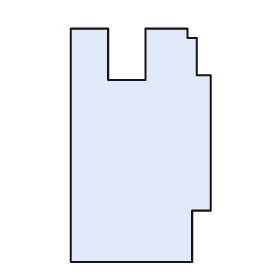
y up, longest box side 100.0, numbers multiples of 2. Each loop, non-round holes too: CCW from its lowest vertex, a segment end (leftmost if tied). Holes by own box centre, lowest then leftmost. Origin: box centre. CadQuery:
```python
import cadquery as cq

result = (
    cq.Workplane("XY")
    .moveTo(-30.0, -50.0)
    .lineTo(22.0, -50.0)
    .lineTo(22.0, -28.0)
    .lineTo(30.0, -28.0)
    .lineTo(30.0, 30.0)
    .lineTo(24.0, 30.0)
    .lineTo(24.0, 46.0)
    .lineTo(20.0, 46.0)
    .lineTo(20.0, 50.0)
    .lineTo(2.0, 50.0)
    .lineTo(2.0, 28.0)
    .lineTo(-14.0, 28.0)
    .lineTo(-14.0, 50.0)
    .lineTo(-30.0, 50.0)
    .close()
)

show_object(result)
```